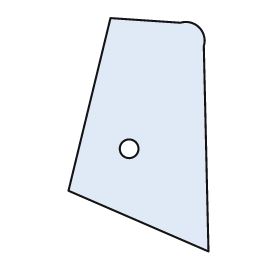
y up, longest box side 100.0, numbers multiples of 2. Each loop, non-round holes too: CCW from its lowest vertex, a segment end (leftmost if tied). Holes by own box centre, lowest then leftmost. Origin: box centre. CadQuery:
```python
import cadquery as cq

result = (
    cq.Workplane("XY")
    .moveTo(30.0, -50.0)
    .lineTo(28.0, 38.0)
    .threePointArc((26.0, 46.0), (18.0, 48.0))
    .lineTo(-12.0, 50.0)
    .lineTo(-30.0, -24.0)
    .close()
    .moveTo(-4.0, -6.0)
    .circle(4.0)
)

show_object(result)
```